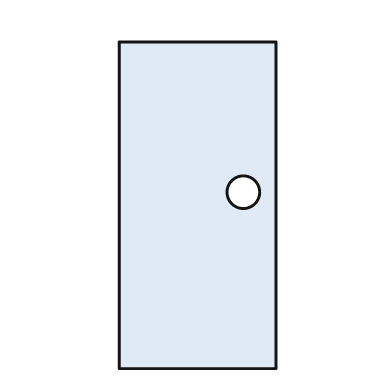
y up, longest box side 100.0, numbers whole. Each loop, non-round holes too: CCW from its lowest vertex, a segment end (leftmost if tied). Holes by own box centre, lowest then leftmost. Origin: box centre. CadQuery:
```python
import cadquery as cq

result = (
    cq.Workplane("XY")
    .moveTo(-24.0, -50.0)
    .lineTo(24.0, -50.0)
    .lineTo(24.0, 50.0)
    .lineTo(-24.0, 50.0)
    .close()
    .moveTo(14.0, 4.0)
    .circle(5.0)
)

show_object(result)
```